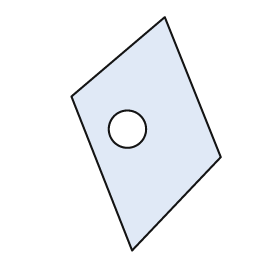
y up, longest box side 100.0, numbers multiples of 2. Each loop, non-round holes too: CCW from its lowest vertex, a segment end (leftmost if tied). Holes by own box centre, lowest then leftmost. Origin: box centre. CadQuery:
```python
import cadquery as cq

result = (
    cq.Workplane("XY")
    .moveTo(-6.0, -50.0)
    .lineTo(32.0, -10.0)
    .lineTo(8.0, 50.0)
    .lineTo(-32.0, 16.0)
    .close()
    .moveTo(-8.0, 2.0)
    .circle(8.0)
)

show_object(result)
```